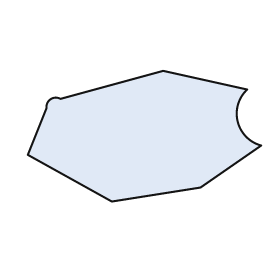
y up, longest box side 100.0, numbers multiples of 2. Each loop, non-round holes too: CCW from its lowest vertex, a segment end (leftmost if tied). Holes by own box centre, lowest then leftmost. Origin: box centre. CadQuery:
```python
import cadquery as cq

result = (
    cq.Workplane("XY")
    .moveTo(-14.0, -28.0)
    .lineTo(24.0, -22.0)
    .lineTo(50.0, -4.0)
    .threePointArc((40.0, 6.0), (44.0, 20.0))
    .lineTo(8.0, 28.0)
    .lineTo(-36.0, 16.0)
    .threePointArc((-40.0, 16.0), (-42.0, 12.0))
    .lineTo(-50.0, -8.0)
    .close()
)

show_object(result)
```